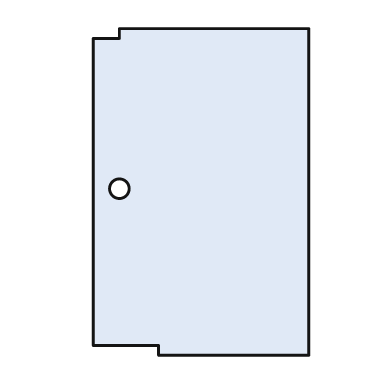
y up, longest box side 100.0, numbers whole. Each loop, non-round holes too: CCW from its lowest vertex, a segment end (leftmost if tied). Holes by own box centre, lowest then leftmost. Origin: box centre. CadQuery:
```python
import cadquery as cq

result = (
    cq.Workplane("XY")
    .moveTo(-13.0, -50.0)
    .lineTo(33.0, -50.0)
    .lineTo(33.0, 50.0)
    .lineTo(-25.0, 50.0)
    .lineTo(-25.0, 47.0)
    .lineTo(-33.0, 47.0)
    .lineTo(-33.0, -47.0)
    .lineTo(-13.0, -47.0)
    .close()
    .moveTo(-25.0, 1.0)
    .circle(3.0)
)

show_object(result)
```